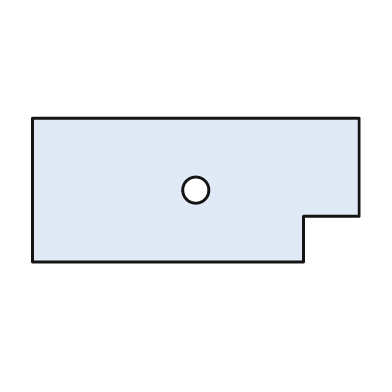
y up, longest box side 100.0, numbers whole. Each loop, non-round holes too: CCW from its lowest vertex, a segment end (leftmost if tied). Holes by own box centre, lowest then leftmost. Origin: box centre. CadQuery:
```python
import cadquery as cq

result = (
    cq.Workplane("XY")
    .moveTo(-50.0, -22.0)
    .lineTo(33.0, -22.0)
    .lineTo(33.0, -8.0)
    .lineTo(50.0, -8.0)
    .lineTo(50.0, 22.0)
    .lineTo(-50.0, 22.0)
    .close()
    .moveTo(0.0, 0.0)
    .circle(4.0)
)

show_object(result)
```